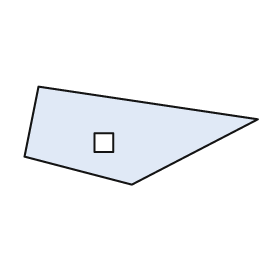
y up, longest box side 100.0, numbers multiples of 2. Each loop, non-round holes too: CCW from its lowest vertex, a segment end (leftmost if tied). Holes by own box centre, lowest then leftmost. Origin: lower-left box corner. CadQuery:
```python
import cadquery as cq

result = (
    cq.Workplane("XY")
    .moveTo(46.0, 0.0)
    .lineTo(100.0, 28.0)
    .lineTo(6.0, 42.0)
    .lineTo(0.0, 12.0)
    .close()
    .moveTo(30.0, 14.0)
    .lineTo(38.0, 14.0)
    .lineTo(38.0, 22.0)
    .lineTo(30.0, 22.0)
    .close()
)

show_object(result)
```